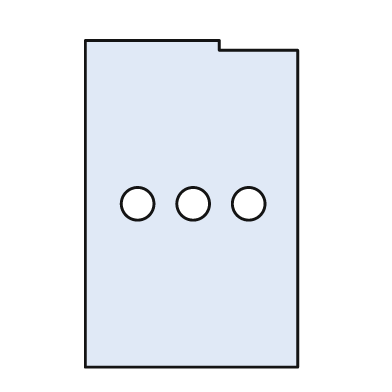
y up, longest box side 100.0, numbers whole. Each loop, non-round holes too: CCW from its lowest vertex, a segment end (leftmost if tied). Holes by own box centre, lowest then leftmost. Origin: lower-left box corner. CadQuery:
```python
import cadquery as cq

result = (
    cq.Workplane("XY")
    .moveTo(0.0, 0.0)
    .lineTo(65.0, 0.0)
    .lineTo(65.0, 97.0)
    .lineTo(41.0, 97.0)
    .lineTo(41.0, 100.0)
    .lineTo(0.0, 100.0)
    .close()
    .moveTo(16.0, 50.0)
    .circle(5.0)
    .moveTo(33.0, 50.0)
    .circle(5.0)
    .moveTo(50.0, 50.0)
    .circle(5.0)
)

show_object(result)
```